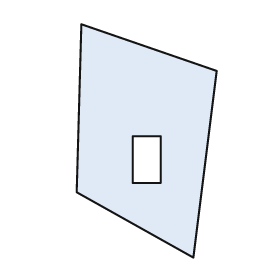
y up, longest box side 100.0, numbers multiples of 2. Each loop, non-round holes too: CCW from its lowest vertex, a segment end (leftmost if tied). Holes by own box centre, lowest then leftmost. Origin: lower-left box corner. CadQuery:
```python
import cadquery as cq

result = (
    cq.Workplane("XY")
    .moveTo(50.0, 0.0)
    .lineTo(60.0, 80.0)
    .lineTo(2.0, 100.0)
    .lineTo(0.0, 28.0)
    .close()
    .moveTo(24.0, 32.0)
    .lineTo(36.0, 32.0)
    .lineTo(36.0, 52.0)
    .lineTo(24.0, 52.0)
    .close()
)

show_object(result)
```